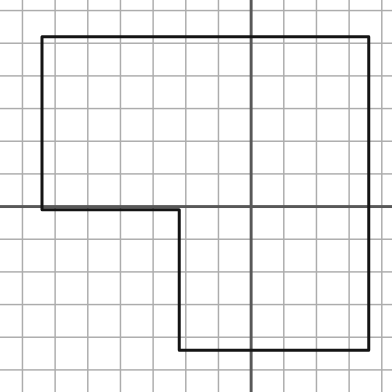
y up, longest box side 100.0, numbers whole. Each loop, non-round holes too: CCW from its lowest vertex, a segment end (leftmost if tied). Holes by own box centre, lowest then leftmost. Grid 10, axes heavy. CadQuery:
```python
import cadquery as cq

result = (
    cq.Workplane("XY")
    .moveTo(-22.0, -44.0)
    .lineTo(36.0, -44.0)
    .lineTo(36.0, 52.0)
    .lineTo(-64.0, 52.0)
    .lineTo(-64.0, -1.0)
    .lineTo(-22.0, -1.0)
    .close()
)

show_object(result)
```